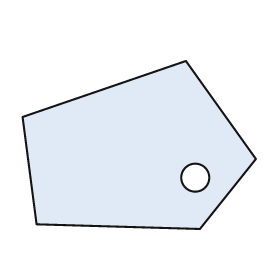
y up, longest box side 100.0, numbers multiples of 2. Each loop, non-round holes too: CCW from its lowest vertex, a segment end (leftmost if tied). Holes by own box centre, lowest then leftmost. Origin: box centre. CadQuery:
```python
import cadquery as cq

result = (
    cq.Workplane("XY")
    .moveTo(26.0, -36.0)
    .lineTo(50.0, -6.0)
    .lineTo(20.0, 36.0)
    .lineTo(-50.0, 12.0)
    .lineTo(-44.0, -34.0)
    .close()
    .moveTo(24.0, -14.0)
    .circle(6.0)
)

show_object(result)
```